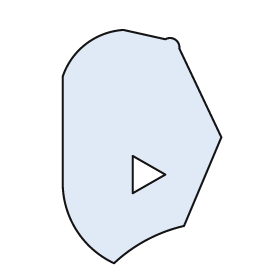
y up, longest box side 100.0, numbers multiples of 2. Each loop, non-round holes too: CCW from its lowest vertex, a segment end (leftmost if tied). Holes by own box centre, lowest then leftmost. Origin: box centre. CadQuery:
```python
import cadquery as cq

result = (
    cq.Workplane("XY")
    .moveTo(-12.0, -50.0)
    .threePointArc((2.0, -40.0), (18.0, -34.0))
    .lineTo(34.0, 4.0)
    .lineTo(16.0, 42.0)
    .threePointArc((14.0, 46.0), (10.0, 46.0))
    .lineTo(-8.0, 50.0)
    .threePointArc((-24.0, 44.0), (-34.0, 30.0))
    .lineTo(-34.0, -16.0)
    .threePointArc((-28.0, -36.0), (-12.0, -50.0))
    .close()
    .moveTo(-4.0, -20.0)
    .lineTo(10.0, -12.0)
    .lineTo(-4.0, -4.0)
    .close()
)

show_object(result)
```